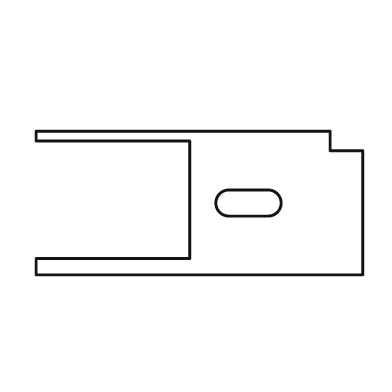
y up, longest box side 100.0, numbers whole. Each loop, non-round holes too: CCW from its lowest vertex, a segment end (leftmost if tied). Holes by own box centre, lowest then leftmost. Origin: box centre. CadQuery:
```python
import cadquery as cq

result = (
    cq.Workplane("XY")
    .moveTo(-50.0, -22.0)
    .lineTo(50.0, -22.0)
    .lineTo(50.0, 16.0)
    .lineTo(40.0, 16.0)
    .lineTo(40.0, 22.0)
    .lineTo(-50.0, 22.0)
    .lineTo(-50.0, 19.0)
    .lineTo(-3.0, 19.0)
    .lineTo(-3.0, -17.0)
    .lineTo(-50.0, -17.0)
    .close()
    .moveTo(9.0, -4.0)
    .lineTo(21.0, -4.0)
    .threePointArc((25.0, 0.0), (21.0, 4.0))
    .lineTo(9.0, 4.0)
    .threePointArc((5.0, 0.0), (9.0, -4.0))
    .close()
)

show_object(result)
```